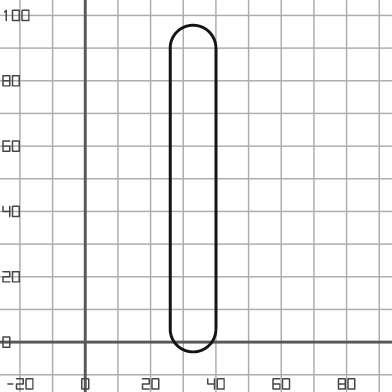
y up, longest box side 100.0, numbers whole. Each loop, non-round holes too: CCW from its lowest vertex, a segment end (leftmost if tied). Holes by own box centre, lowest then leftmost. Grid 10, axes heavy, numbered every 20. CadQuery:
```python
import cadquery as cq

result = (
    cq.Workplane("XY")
    .moveTo(26.0, 4.0)
    .threePointArc((33.0, -3.0), (40.0, 4.0))
    .lineTo(40.0, 90.0)
    .threePointArc((33.0, 97.0), (26.0, 90.0))
    .close()
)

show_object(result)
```